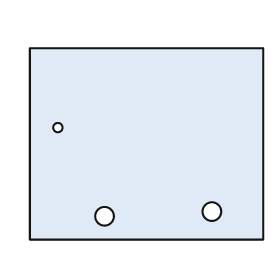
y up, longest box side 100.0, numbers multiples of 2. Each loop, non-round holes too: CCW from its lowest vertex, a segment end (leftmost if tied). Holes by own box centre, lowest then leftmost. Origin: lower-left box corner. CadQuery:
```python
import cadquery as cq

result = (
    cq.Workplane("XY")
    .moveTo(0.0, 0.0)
    .lineTo(100.0, 0.0)
    .lineTo(100.0, 82.0)
    .lineTo(0.0, 82.0)
    .close()
    .moveTo(32.0, 10.0)
    .circle(4.0)
    .moveTo(78.0, 12.0)
    .circle(4.0)
    .moveTo(12.0, 48.0)
    .circle(2.0)
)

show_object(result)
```